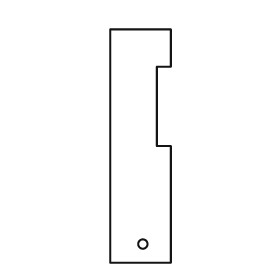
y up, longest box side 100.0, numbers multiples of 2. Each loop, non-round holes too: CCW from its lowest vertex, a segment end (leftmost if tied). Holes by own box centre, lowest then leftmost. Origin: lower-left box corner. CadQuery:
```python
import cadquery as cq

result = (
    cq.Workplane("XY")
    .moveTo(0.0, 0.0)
    .lineTo(26.0, 0.0)
    .lineTo(26.0, 50.0)
    .lineTo(20.0, 50.0)
    .lineTo(20.0, 84.0)
    .lineTo(26.0, 84.0)
    .lineTo(26.0, 100.0)
    .lineTo(0.0, 100.0)
    .close()
    .moveTo(14.0, 8.0)
    .circle(2.0)
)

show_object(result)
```